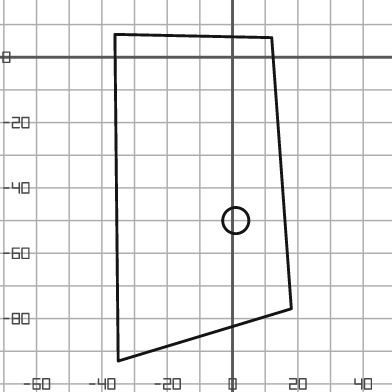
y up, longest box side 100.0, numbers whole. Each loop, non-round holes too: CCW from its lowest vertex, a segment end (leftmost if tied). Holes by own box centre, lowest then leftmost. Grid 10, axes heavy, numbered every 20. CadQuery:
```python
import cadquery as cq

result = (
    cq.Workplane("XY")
    .moveTo(-35.0, -93.0)
    .lineTo(18.0, -77.0)
    .lineTo(12.0, 6.0)
    .lineTo(-36.0, 7.0)
    .close()
    .moveTo(1.0, -50.0)
    .circle(4.0)
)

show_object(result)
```